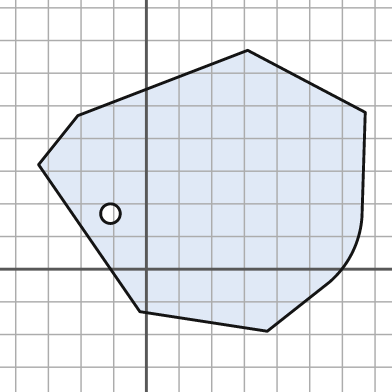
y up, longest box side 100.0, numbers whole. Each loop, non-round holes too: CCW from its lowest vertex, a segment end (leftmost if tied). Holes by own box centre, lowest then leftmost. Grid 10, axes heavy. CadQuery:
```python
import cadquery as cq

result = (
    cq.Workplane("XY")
    .moveTo(37.0, -19.0)
    .lineTo(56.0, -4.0)
    .threePointArc((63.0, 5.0), (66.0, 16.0))
    .lineTo(67.0, 48.0)
    .lineTo(31.0, 67.0)
    .lineTo(-21.0, 47.0)
    .lineTo(-33.0, 32.0)
    .lineTo(-2.0, -13.0)
    .close()
    .moveTo(-11.0, 17.0)
    .circle(3.0)
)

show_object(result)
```